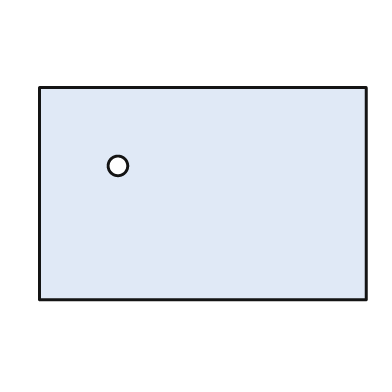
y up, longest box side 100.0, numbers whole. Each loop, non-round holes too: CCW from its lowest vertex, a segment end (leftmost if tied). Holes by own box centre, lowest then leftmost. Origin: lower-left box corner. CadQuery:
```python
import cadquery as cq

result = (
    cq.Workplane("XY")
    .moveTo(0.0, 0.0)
    .lineTo(100.0, 0.0)
    .lineTo(100.0, 65.0)
    .lineTo(0.0, 65.0)
    .close()
    .moveTo(24.0, 41.0)
    .circle(3.0)
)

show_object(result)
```